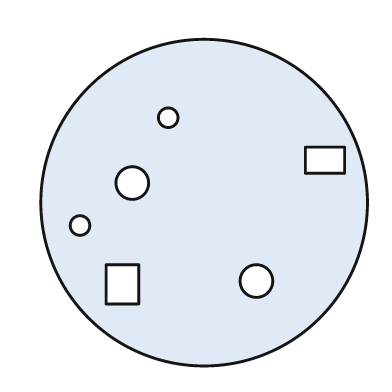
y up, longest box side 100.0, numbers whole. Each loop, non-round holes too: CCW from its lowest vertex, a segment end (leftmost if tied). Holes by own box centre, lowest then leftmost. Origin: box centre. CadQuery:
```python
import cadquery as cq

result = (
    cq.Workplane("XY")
    .moveTo(0.0, 0.0)
    .circle(50.0)
    .moveTo(-30.0, -31.0)
    .lineTo(-20.0, -31.0)
    .lineTo(-20.0, -19.0)
    .lineTo(-30.0, -19.0)
    .close()
    .moveTo(16.0, -24.0)
    .circle(5.0)
    .moveTo(-38.0, -7.0)
    .circle(3.0)
    .moveTo(-22.0, 6.0)
    .circle(5.0)
    .moveTo(31.0, 9.0)
    .lineTo(43.0, 9.0)
    .lineTo(43.0, 17.0)
    .lineTo(31.0, 17.0)
    .close()
    .moveTo(-11.0, 26.0)
    .circle(3.0)
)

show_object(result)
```